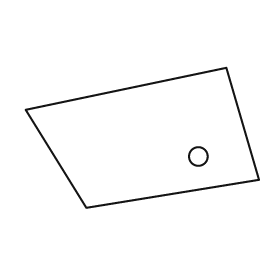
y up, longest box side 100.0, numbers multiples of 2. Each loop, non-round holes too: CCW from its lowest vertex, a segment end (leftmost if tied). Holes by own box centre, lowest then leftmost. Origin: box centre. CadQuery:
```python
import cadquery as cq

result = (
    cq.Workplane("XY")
    .moveTo(-24.0, -30.0)
    .lineTo(50.0, -18.0)
    .lineTo(36.0, 30.0)
    .lineTo(-50.0, 12.0)
    .close()
    .moveTo(24.0, -8.0)
    .circle(4.0)
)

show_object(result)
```